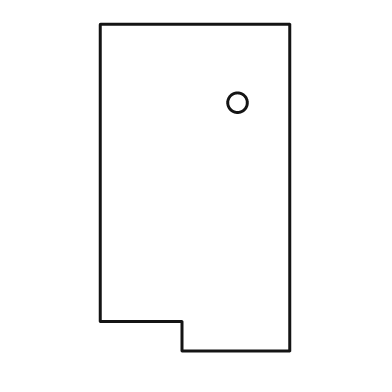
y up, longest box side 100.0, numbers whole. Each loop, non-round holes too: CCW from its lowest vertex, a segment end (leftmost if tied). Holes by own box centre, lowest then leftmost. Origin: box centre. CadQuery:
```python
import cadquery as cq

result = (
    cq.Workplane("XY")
    .moveTo(-4.0, -50.0)
    .lineTo(29.0, -50.0)
    .lineTo(29.0, 50.0)
    .lineTo(-29.0, 50.0)
    .lineTo(-29.0, -41.0)
    .lineTo(-4.0, -41.0)
    .close()
    .moveTo(13.0, 26.0)
    .circle(3.0)
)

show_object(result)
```